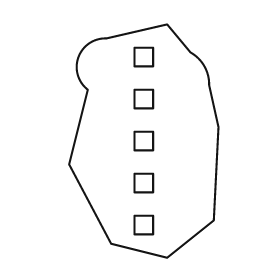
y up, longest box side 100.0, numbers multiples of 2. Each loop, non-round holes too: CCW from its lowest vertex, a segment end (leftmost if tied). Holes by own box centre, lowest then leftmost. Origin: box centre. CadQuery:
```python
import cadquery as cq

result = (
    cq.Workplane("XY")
    .moveTo(10.0, -50.0)
    .lineTo(30.0, -34.0)
    .lineTo(32.0, 6.0)
    .lineTo(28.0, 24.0)
    .threePointArc((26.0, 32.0), (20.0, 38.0))
    .lineTo(10.0, 50.0)
    .lineTo(-16.0, 44.0)
    .threePointArc((-28.0, 36.0), (-24.0, 22.0))
    .lineTo(-32.0, -10.0)
    .lineTo(-14.0, -44.0)
    .close()
    .moveTo(-4.0, -40.0)
    .lineTo(4.0, -40.0)
    .lineTo(4.0, -32.0)
    .lineTo(-4.0, -32.0)
    .close()
    .moveTo(-4.0, -22.0)
    .lineTo(4.0, -22.0)
    .lineTo(4.0, -14.0)
    .lineTo(-4.0, -14.0)
    .close()
    .moveTo(-4.0, -4.0)
    .lineTo(4.0, -4.0)
    .lineTo(4.0, 4.0)
    .lineTo(-4.0, 4.0)
    .close()
    .moveTo(-4.0, 14.0)
    .lineTo(4.0, 14.0)
    .lineTo(4.0, 22.0)
    .lineTo(-4.0, 22.0)
    .close()
    .moveTo(-4.0, 32.0)
    .lineTo(4.0, 32.0)
    .lineTo(4.0, 40.0)
    .lineTo(-4.0, 40.0)
    .close()
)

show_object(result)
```